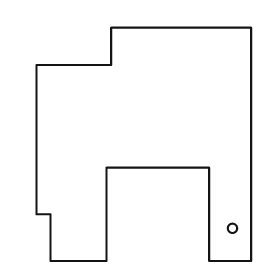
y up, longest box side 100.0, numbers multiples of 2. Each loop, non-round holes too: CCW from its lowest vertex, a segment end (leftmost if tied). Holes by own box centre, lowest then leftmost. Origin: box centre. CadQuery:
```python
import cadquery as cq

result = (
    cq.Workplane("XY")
    .moveTo(-40.0, -50.0)
    .lineTo(-16.0, -50.0)
    .lineTo(-16.0, -10.0)
    .lineTo(28.0, -10.0)
    .lineTo(28.0, -50.0)
    .lineTo(46.0, -50.0)
    .lineTo(46.0, 50.0)
    .lineTo(-14.0, 50.0)
    .lineTo(-14.0, 34.0)
    .lineTo(-46.0, 34.0)
    .lineTo(-46.0, -30.0)
    .lineTo(-40.0, -30.0)
    .close()
    .moveTo(38.0, -36.0)
    .circle(2.0)
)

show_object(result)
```